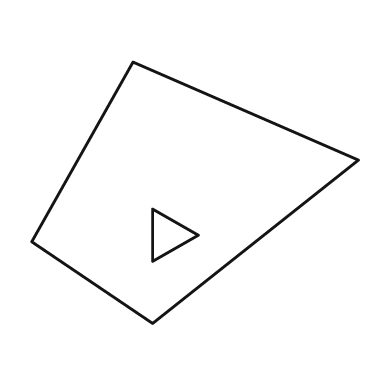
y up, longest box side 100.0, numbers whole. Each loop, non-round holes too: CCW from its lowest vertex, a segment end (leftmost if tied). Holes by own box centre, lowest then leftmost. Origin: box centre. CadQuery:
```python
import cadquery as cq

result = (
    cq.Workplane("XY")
    .moveTo(-13.0, -40.0)
    .lineTo(50.0, 10.0)
    .lineTo(-19.0, 40.0)
    .lineTo(-50.0, -15.0)
    .close()
    .moveTo(-13.0, -21.0)
    .lineTo(1.0, -13.0)
    .lineTo(-13.0, -5.0)
    .close()
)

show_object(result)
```